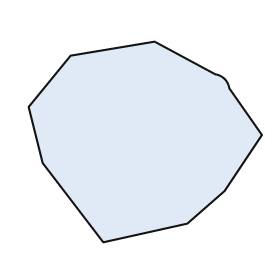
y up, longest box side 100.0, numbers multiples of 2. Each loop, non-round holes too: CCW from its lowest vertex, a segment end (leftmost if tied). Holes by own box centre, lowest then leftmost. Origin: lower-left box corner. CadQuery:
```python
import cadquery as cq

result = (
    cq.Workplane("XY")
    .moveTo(32.0, 0.0)
    .lineTo(68.0, 8.0)
    .lineTo(84.0, 22.0)
    .lineTo(100.0, 46.0)
    .lineTo(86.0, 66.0)
    .threePointArc((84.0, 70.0), (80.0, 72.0))
    .lineTo(54.0, 86.0)
    .lineTo(18.0, 80.0)
    .lineTo(0.0, 58.0)
    .lineTo(6.0, 34.0)
    .close()
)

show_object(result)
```